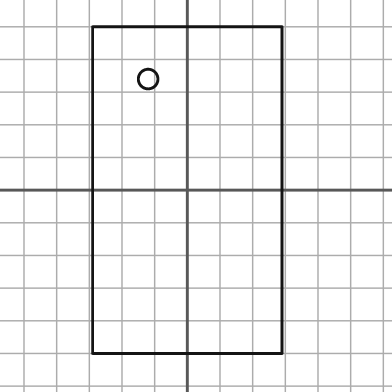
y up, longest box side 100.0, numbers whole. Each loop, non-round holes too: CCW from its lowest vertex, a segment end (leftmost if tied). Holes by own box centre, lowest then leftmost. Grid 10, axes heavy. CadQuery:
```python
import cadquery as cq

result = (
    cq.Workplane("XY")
    .moveTo(-29.0, -50.0)
    .lineTo(29.0, -50.0)
    .lineTo(29.0, 50.0)
    .lineTo(-29.0, 50.0)
    .close()
    .moveTo(-12.0, 34.0)
    .circle(3.0)
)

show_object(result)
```